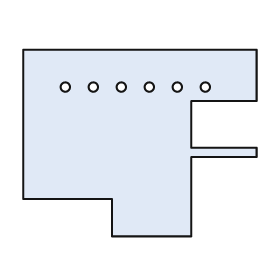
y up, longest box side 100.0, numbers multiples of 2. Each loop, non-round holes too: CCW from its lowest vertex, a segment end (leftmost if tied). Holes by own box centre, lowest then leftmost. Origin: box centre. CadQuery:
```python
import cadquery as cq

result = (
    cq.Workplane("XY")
    .moveTo(-12.0, -40.0)
    .lineTo(22.0, -40.0)
    .lineTo(22.0, -6.0)
    .lineTo(50.0, -6.0)
    .lineTo(50.0, -2.0)
    .lineTo(22.0, -2.0)
    .lineTo(22.0, 18.0)
    .lineTo(50.0, 18.0)
    .lineTo(50.0, 40.0)
    .lineTo(-50.0, 40.0)
    .lineTo(-50.0, -24.0)
    .lineTo(-12.0, -24.0)
    .close()
    .moveTo(-32.0, 24.0)
    .circle(2.0)
    .moveTo(-20.0, 24.0)
    .circle(2.0)
    .moveTo(-8.0, 24.0)
    .circle(2.0)
    .moveTo(4.0, 24.0)
    .circle(2.0)
    .moveTo(16.0, 24.0)
    .circle(2.0)
    .moveTo(28.0, 24.0)
    .circle(2.0)
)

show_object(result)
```